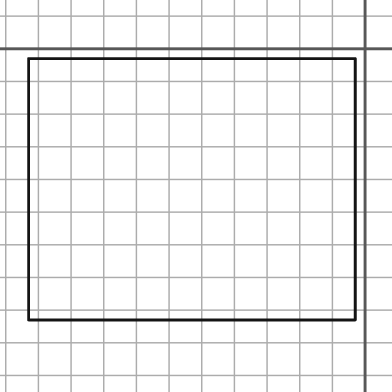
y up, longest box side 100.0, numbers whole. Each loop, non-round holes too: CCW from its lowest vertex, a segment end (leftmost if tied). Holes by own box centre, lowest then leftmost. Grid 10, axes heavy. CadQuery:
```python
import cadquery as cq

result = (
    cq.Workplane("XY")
    .moveTo(-103.0, -83.0)
    .lineTo(-3.0, -83.0)
    .lineTo(-3.0, -3.0)
    .lineTo(-103.0, -3.0)
    .close()
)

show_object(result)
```